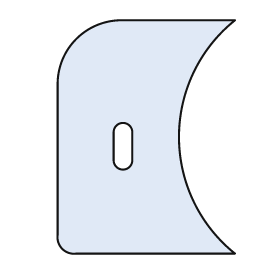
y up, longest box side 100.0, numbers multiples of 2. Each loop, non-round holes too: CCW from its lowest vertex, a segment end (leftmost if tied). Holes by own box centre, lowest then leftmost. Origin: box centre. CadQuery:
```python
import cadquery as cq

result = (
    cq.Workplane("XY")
    .moveTo(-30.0, -50.0)
    .lineTo(38.0, -50.0)
    .threePointArc((14.0, 0.0), (38.0, 50.0))
    .lineTo(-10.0, 50.0)
    .threePointArc((-30.0, 42.0), (-38.0, 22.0))
    .lineTo(-38.0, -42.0)
    .threePointArc((-36.0, -48.0), (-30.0, -50.0))
    .close()
    .moveTo(-14.0, -10.0)
    .threePointArc((-10.0, -14.0), (-6.0, -10.0))
    .lineTo(-6.0, 2.0)
    .threePointArc((-10.0, 6.0), (-14.0, 2.0))
    .close()
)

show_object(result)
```